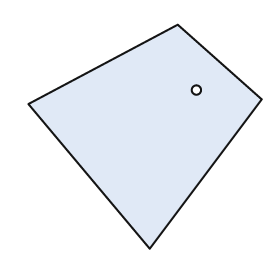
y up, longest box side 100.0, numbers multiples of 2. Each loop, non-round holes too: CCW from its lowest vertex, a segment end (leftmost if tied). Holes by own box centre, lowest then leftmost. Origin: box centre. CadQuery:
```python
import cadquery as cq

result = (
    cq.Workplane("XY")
    .moveTo(2.0, -48.0)
    .lineTo(50.0, 16.0)
    .lineTo(14.0, 48.0)
    .lineTo(-50.0, 14.0)
    .close()
    .moveTo(22.0, 20.0)
    .circle(2.0)
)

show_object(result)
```